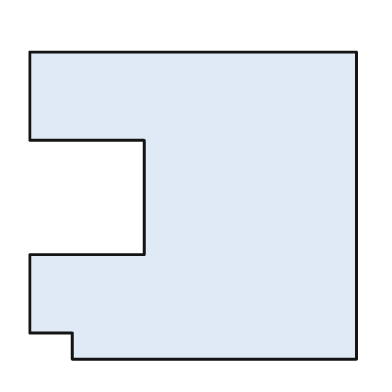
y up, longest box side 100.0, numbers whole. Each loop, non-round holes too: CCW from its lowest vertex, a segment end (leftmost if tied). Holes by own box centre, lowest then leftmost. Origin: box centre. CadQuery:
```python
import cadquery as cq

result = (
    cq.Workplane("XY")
    .moveTo(-37.0, -47.0)
    .lineTo(50.0, -47.0)
    .lineTo(50.0, 47.0)
    .lineTo(-50.0, 47.0)
    .lineTo(-50.0, 20.0)
    .lineTo(-15.0, 20.0)
    .lineTo(-15.0, -15.0)
    .lineTo(-50.0, -15.0)
    .lineTo(-50.0, -39.0)
    .lineTo(-37.0, -39.0)
    .close()
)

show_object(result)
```